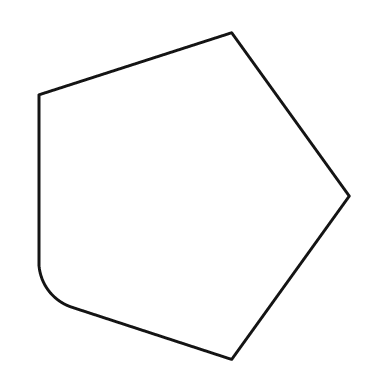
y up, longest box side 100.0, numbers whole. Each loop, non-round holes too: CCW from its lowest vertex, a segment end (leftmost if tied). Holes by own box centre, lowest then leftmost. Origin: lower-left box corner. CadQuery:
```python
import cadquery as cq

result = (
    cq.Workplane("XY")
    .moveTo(59.0, 0.0)
    .lineTo(95.0, 50.0)
    .lineTo(59.0, 100.0)
    .lineTo(0.0, 81.0)
    .lineTo(0.0, 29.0)
    .threePointArc((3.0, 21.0), (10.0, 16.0))
    .close()
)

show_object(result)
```